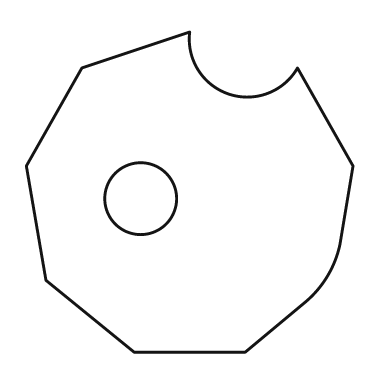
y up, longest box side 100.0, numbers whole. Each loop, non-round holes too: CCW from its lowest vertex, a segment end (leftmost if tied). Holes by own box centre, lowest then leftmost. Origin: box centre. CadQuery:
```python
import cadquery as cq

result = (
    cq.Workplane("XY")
    .moveTo(-17.0, -49.0)
    .lineTo(17.0, -49.0)
    .lineTo(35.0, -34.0)
    .threePointArc((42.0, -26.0), (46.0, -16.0))
    .lineTo(50.0, 8.0)
    .lineTo(33.0, 38.0)
    .threePointArc((12.0, 30.0), (0.0, 49.0))
    .lineTo(-33.0, 38.0)
    .lineTo(-50.0, 8.0)
    .lineTo(-44.0, -27.0)
    .close()
    .moveTo(-15.0, -2.0)
    .circle(11.0)
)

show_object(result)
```